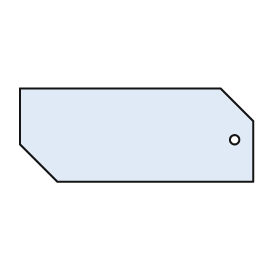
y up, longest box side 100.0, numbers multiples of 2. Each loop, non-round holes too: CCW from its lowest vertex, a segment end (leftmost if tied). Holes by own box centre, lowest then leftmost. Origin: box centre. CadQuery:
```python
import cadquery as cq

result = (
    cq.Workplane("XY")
    .moveTo(-34.0, -20.0)
    .lineTo(50.0, -20.0)
    .lineTo(50.0, 6.0)
    .lineTo(36.0, 20.0)
    .lineTo(-50.0, 20.0)
    .lineTo(-50.0, -4.0)
    .close()
    .moveTo(42.0, -2.0)
    .circle(2.0)
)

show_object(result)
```